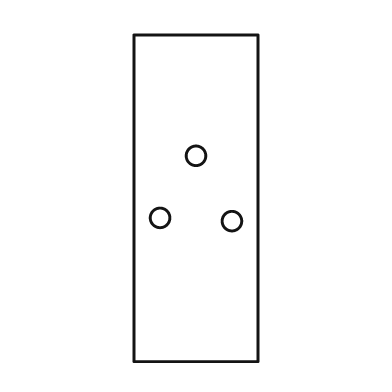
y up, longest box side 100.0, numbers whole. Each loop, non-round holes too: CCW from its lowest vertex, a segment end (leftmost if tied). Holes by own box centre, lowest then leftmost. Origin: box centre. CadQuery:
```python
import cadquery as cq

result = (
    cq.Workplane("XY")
    .moveTo(-19.0, -50.0)
    .lineTo(19.0, -50.0)
    .lineTo(19.0, 50.0)
    .lineTo(-19.0, 50.0)
    .close()
    .moveTo(11.0, -7.0)
    .circle(3.0)
    .moveTo(-11.0, -6.0)
    .circle(3.0)
    .moveTo(0.0, 13.0)
    .circle(3.0)
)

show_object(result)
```